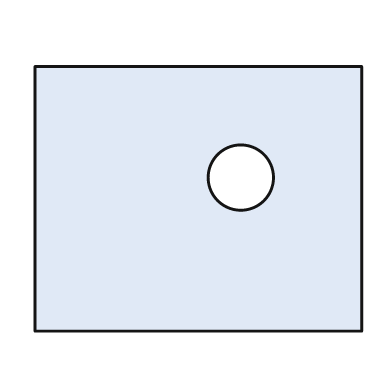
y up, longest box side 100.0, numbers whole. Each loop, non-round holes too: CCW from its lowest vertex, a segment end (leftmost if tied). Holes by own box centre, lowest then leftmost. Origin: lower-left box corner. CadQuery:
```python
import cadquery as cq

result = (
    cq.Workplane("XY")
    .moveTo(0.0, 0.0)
    .lineTo(100.0, 0.0)
    .lineTo(100.0, 81.0)
    .lineTo(0.0, 81.0)
    .close()
    .moveTo(63.0, 47.0)
    .circle(10.0)
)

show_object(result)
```